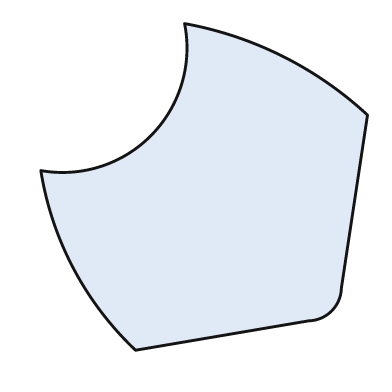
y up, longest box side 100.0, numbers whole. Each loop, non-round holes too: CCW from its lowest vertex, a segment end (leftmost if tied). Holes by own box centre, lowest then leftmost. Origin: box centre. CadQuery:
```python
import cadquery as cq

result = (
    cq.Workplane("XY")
    .moveTo(-21.0, -50.0)
    .lineTo(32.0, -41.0)
    .threePointArc((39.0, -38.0), (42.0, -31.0))
    .lineTo(50.0, 22.0)
    .threePointArc((24.0, 40.0), (-6.0, 50.0))
    .threePointArc((-16.0, 16.0), (-50.0, 5.0))
    .threePointArc((-40.0, -25.0), (-21.0, -50.0))
    .close()
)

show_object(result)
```